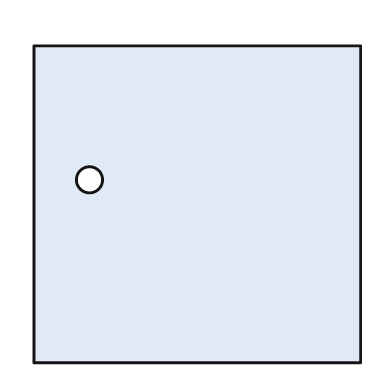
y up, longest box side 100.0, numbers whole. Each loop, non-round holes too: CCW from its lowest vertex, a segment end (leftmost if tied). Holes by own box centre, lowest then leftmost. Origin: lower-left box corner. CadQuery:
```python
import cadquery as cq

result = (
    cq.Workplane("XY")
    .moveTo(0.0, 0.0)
    .lineTo(100.0, 0.0)
    .lineTo(100.0, 97.0)
    .lineTo(0.0, 97.0)
    .close()
    .moveTo(17.0, 56.0)
    .circle(4.0)
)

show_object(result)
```